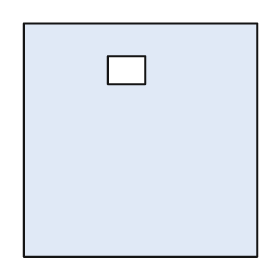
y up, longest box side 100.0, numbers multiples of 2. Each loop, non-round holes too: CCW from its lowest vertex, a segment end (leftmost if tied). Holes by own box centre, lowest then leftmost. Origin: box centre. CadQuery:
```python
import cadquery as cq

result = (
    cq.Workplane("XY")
    .moveTo(-50.0, -50.0)
    .lineTo(50.0, -50.0)
    .lineTo(50.0, 50.0)
    .lineTo(-50.0, 50.0)
    .close()
    .moveTo(-14.0, 24.0)
    .lineTo(2.0, 24.0)
    .lineTo(2.0, 36.0)
    .lineTo(-14.0, 36.0)
    .close()
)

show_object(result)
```